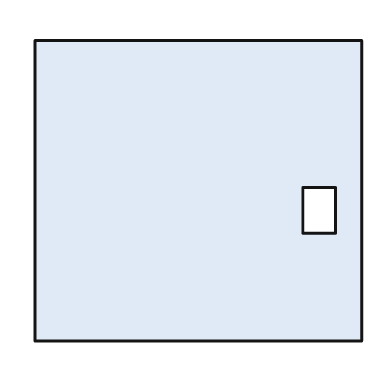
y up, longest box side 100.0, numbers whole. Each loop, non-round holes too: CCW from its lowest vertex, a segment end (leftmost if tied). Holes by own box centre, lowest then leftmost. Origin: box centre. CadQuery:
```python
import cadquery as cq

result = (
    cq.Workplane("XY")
    .moveTo(-50.0, -46.0)
    .lineTo(50.0, -46.0)
    .lineTo(50.0, 46.0)
    .lineTo(-50.0, 46.0)
    .close()
    .moveTo(32.0, -13.0)
    .lineTo(42.0, -13.0)
    .lineTo(42.0, 1.0)
    .lineTo(32.0, 1.0)
    .close()
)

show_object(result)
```